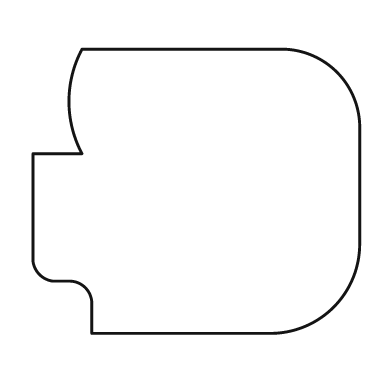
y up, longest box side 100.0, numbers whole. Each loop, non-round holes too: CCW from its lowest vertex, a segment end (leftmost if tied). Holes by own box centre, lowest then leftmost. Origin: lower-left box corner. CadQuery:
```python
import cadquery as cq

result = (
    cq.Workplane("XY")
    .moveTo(18.0, 0.0)
    .lineTo(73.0, 0.0)
    .threePointArc((92.0, 8.0), (100.0, 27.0))
    .lineTo(100.0, 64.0)
    .threePointArc((93.0, 80.0), (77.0, 87.0))
    .lineTo(15.0, 87.0)
    .threePointArc((11.0, 71.0), (15.0, 55.0))
    .lineTo(0.0, 55.0)
    .lineTo(0.0, 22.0)
    .threePointArc((2.0, 18.0), (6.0, 16.0))
    .lineTo(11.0, 16.0)
    .threePointArc((16.0, 14.0), (18.0, 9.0))
    .close()
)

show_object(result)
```